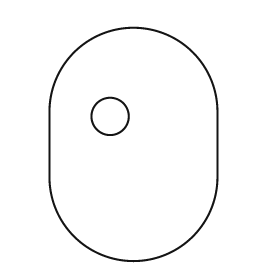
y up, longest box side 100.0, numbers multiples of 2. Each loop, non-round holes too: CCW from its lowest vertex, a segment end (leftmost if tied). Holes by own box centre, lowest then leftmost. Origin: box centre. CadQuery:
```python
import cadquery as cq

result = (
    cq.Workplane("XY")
    .moveTo(-36.0, -14.0)
    .threePointArc((0.0, -50.0), (36.0, -14.0))
    .lineTo(36.0, 14.0)
    .threePointArc((0.0, 50.0), (-36.0, 14.0))
    .close()
    .moveTo(-10.0, 12.0)
    .circle(8.0)
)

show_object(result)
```